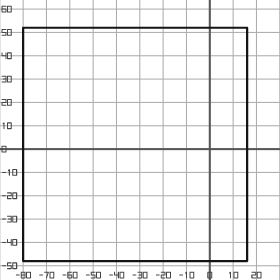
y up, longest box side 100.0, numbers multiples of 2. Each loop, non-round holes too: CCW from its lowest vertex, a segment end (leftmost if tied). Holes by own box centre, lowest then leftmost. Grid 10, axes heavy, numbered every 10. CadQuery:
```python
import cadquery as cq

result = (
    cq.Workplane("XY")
    .moveTo(-80.0, -48.0)
    .lineTo(16.0, -48.0)
    .lineTo(16.0, 52.0)
    .lineTo(-80.0, 52.0)
    .close()
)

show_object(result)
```